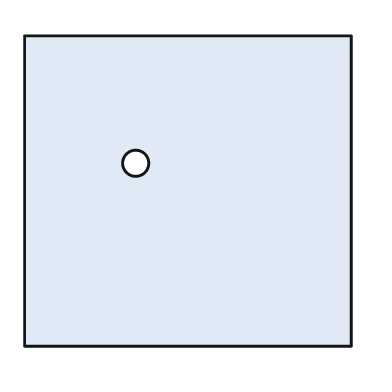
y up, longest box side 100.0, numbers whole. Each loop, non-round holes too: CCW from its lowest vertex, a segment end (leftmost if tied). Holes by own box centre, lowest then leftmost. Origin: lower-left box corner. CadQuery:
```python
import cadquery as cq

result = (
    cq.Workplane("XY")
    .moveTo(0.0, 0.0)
    .lineTo(100.0, 0.0)
    .lineTo(100.0, 95.0)
    .lineTo(0.0, 95.0)
    .close()
    .moveTo(34.0, 56.0)
    .circle(4.0)
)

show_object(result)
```